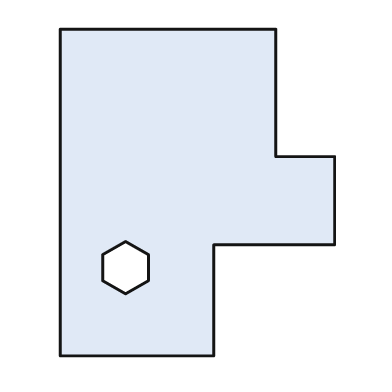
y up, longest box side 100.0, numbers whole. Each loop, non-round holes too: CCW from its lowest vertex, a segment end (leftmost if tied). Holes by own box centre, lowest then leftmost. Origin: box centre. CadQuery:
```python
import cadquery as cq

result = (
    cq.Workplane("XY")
    .moveTo(-42.0, -50.0)
    .lineTo(5.0, -50.0)
    .lineTo(5.0, -16.0)
    .lineTo(42.0, -16.0)
    .lineTo(42.0, 11.0)
    .lineTo(24.0, 11.0)
    .lineTo(24.0, 50.0)
    .lineTo(-42.0, 50.0)
    .close()
    .moveTo(-22.0, -31.0)
    .lineTo(-15.0, -27.0)
    .lineTo(-15.0, -19.0)
    .lineTo(-22.0, -15.0)
    .lineTo(-29.0, -19.0)
    .lineTo(-29.0, -27.0)
    .close()
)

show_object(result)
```